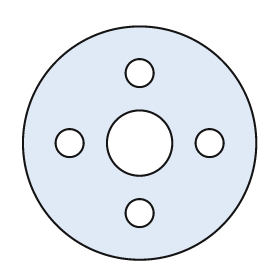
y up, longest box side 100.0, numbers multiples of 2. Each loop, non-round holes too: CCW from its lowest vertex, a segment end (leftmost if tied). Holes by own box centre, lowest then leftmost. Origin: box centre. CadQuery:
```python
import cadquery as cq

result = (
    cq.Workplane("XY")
    .moveTo(0.0, 0.0)
    .circle(50.0)
    .moveTo(0.0, -30.0)
    .circle(6.0)
    .moveTo(-30.0, 0.0)
    .circle(6.0)
    .moveTo(0.0, 0.0)
    .circle(14.0)
    .moveTo(30.0, 0.0)
    .circle(6.0)
    .moveTo(0.0, 30.0)
    .circle(6.0)
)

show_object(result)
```